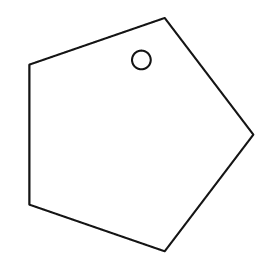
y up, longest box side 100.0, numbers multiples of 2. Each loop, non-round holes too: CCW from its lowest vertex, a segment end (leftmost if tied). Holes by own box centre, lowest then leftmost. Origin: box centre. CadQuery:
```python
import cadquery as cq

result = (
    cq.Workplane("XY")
    .moveTo(10.0, -50.0)
    .lineTo(48.0, 0.0)
    .lineTo(10.0, 50.0)
    .lineTo(-48.0, 30.0)
    .lineTo(-48.0, -30.0)
    .close()
    .moveTo(0.0, 32.0)
    .circle(4.0)
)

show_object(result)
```